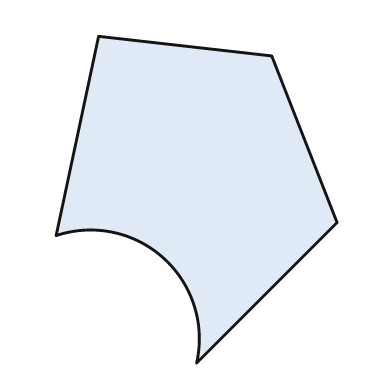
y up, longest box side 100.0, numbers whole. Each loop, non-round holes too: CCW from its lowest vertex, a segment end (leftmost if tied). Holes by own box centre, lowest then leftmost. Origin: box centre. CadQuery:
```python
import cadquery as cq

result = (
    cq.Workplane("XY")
    .moveTo(0.0, -50.0)
    .lineTo(43.0, -7.0)
    .lineTo(23.0, 44.0)
    .lineTo(-30.0, 50.0)
    .lineTo(-43.0, -11.0)
    .threePointArc((-10.0, -18.0), (0.0, -50.0))
    .close()
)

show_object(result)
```